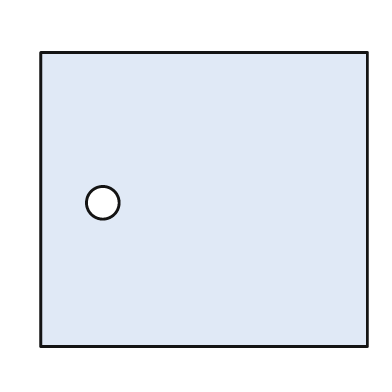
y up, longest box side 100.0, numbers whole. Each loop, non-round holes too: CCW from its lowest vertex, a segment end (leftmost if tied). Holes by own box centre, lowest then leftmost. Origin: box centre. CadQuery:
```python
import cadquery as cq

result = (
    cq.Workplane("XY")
    .moveTo(-50.0, -45.0)
    .lineTo(50.0, -45.0)
    .lineTo(50.0, 45.0)
    .lineTo(-50.0, 45.0)
    .close()
    .moveTo(-31.0, -1.0)
    .circle(5.0)
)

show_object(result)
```